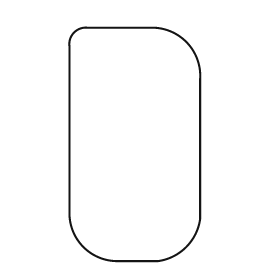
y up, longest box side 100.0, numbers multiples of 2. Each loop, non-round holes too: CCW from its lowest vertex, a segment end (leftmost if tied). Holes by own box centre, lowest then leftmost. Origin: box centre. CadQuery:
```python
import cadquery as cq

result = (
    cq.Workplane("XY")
    .moveTo(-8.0, -50.0)
    .lineTo(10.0, -50.0)
    .threePointArc((22.0, -44.0), (28.0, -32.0))
    .lineTo(28.0, 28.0)
    .threePointArc((22.0, 44.0), (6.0, 50.0))
    .lineTo(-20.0, 50.0)
    .threePointArc((-26.0, 48.0), (-28.0, 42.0))
    .lineTo(-28.0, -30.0)
    .threePointArc((-22.0, -44.0), (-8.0, -50.0))
    .close()
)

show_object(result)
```